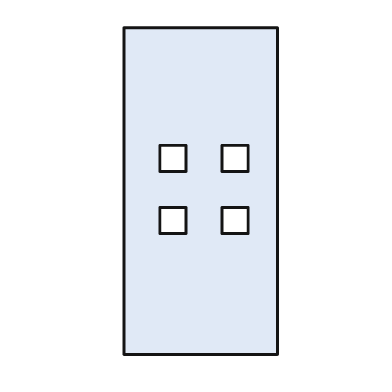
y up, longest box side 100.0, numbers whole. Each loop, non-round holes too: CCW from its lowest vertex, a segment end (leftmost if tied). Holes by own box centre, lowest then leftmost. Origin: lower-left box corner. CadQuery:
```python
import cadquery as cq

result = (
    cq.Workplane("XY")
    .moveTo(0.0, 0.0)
    .lineTo(47.0, 0.0)
    .lineTo(47.0, 100.0)
    .lineTo(0.0, 100.0)
    .close()
    .moveTo(11.0, 37.0)
    .lineTo(19.0, 37.0)
    .lineTo(19.0, 45.0)
    .lineTo(11.0, 45.0)
    .close()
    .moveTo(30.0, 37.0)
    .lineTo(38.0, 37.0)
    .lineTo(38.0, 45.0)
    .lineTo(30.0, 45.0)
    .close()
    .moveTo(11.0, 56.0)
    .lineTo(19.0, 56.0)
    .lineTo(19.0, 64.0)
    .lineTo(11.0, 64.0)
    .close()
    .moveTo(30.0, 56.0)
    .lineTo(38.0, 56.0)
    .lineTo(38.0, 64.0)
    .lineTo(30.0, 64.0)
    .close()
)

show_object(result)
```